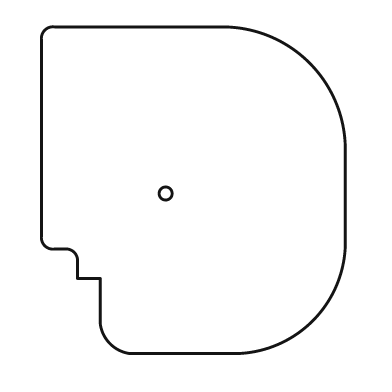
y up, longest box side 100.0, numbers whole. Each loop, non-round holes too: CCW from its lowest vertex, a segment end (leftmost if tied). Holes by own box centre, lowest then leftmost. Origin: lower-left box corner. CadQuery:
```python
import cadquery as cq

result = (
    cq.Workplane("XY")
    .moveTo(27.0, 0.0)
    .lineTo(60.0, 0.0)
    .threePointArc((83.0, 10.0), (93.0, 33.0))
    .lineTo(93.0, 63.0)
    .threePointArc((82.0, 89.0), (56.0, 100.0))
    .lineTo(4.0, 100.0)
    .threePointArc((1.0, 99.0), (0.0, 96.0))
    .lineTo(0.0, 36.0)
    .threePointArc((1.0, 33.0), (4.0, 32.0))
    .lineTo(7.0, 32.0)
    .threePointArc((10.0, 31.0), (11.0, 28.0))
    .lineTo(11.0, 23.0)
    .lineTo(18.0, 23.0)
    .lineTo(18.0, 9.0)
    .threePointArc((21.0, 3.0), (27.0, 0.0))
    .close()
    .moveTo(38.0, 49.0)
    .circle(2.0)
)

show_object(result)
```